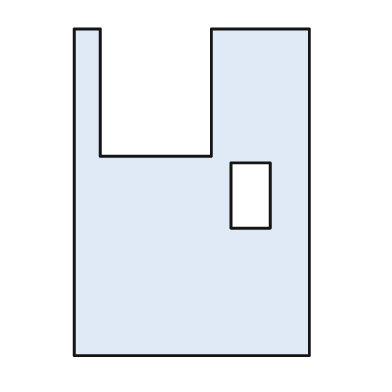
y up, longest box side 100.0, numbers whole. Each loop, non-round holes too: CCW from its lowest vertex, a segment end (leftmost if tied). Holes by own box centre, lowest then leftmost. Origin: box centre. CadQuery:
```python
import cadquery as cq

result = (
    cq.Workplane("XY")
    .moveTo(-36.0, -50.0)
    .lineTo(36.0, -50.0)
    .lineTo(36.0, 50.0)
    .lineTo(6.0, 50.0)
    .lineTo(6.0, 11.0)
    .lineTo(-28.0, 11.0)
    .lineTo(-28.0, 50.0)
    .lineTo(-36.0, 50.0)
    .close()
    .moveTo(12.0, -11.0)
    .lineTo(24.0, -11.0)
    .lineTo(24.0, 9.0)
    .lineTo(12.0, 9.0)
    .close()
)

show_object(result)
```